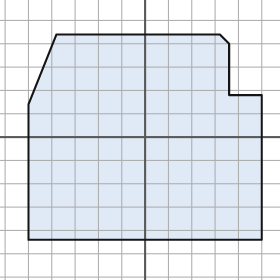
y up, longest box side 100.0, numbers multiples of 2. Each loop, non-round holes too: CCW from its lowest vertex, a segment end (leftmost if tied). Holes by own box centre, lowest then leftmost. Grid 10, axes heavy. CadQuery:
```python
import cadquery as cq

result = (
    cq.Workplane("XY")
    .moveTo(-50.0, -44.0)
    .lineTo(50.0, -44.0)
    .lineTo(50.0, 18.0)
    .lineTo(36.0, 18.0)
    .lineTo(36.0, 40.0)
    .lineTo(32.0, 44.0)
    .lineTo(-38.0, 44.0)
    .lineTo(-50.0, 14.0)
    .close()
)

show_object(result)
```